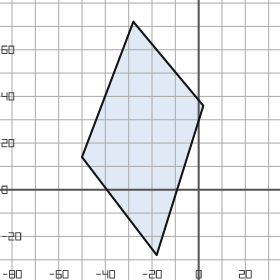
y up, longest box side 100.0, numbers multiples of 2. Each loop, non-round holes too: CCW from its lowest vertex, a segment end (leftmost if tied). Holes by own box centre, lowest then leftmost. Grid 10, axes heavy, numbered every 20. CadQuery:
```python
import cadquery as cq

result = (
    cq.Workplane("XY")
    .moveTo(-18.0, -28.0)
    .lineTo(2.0, 36.0)
    .lineTo(-28.0, 72.0)
    .lineTo(-50.0, 14.0)
    .close()
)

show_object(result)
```